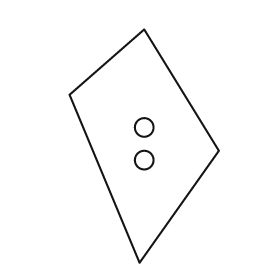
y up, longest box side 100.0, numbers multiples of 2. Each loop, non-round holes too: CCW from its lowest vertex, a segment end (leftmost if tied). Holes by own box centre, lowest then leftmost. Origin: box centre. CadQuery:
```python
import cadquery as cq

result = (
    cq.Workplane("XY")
    .moveTo(-2.0, -50.0)
    .lineTo(32.0, -2.0)
    .lineTo(0.0, 50.0)
    .lineTo(-32.0, 22.0)
    .close()
    .moveTo(0.0, -6.0)
    .circle(4.0)
    .moveTo(0.0, 8.0)
    .circle(4.0)
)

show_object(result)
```